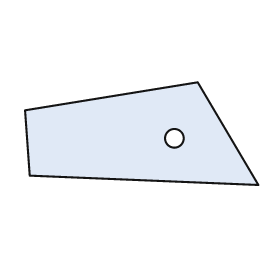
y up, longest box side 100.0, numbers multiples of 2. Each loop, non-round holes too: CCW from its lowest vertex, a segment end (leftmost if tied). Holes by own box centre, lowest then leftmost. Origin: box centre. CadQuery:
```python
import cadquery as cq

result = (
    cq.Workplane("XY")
    .moveTo(50.0, -22.0)
    .lineTo(24.0, 22.0)
    .lineTo(-50.0, 10.0)
    .lineTo(-48.0, -18.0)
    .close()
    .moveTo(14.0, -2.0)
    .circle(4.0)
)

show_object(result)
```